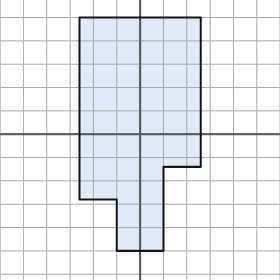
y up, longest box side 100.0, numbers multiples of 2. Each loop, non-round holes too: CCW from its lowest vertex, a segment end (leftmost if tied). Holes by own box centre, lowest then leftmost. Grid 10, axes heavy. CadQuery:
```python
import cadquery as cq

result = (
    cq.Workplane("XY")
    .moveTo(-10.0, -50.0)
    .lineTo(10.0, -50.0)
    .lineTo(10.0, -14.0)
    .lineTo(26.0, -14.0)
    .lineTo(26.0, 50.0)
    .lineTo(-26.0, 50.0)
    .lineTo(-26.0, -28.0)
    .lineTo(-10.0, -28.0)
    .close()
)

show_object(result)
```